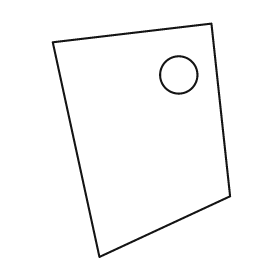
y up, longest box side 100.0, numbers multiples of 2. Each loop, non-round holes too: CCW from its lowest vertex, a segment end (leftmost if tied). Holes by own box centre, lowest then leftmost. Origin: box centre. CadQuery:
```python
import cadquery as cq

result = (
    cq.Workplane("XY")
    .moveTo(-18.0, -50.0)
    .lineTo(38.0, -24.0)
    .lineTo(30.0, 50.0)
    .lineTo(-38.0, 42.0)
    .close()
    .moveTo(16.0, 28.0)
    .circle(8.0)
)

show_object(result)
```